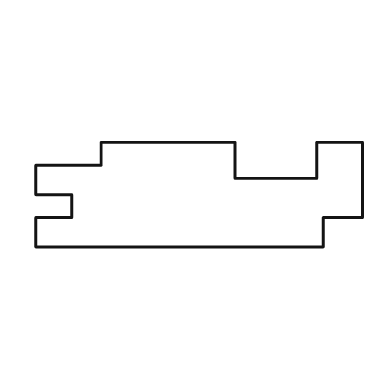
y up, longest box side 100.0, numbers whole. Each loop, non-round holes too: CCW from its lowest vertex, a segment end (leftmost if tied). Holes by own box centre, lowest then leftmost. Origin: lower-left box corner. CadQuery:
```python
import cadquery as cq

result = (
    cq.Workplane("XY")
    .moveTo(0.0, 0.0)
    .lineTo(88.0, 0.0)
    .lineTo(88.0, 9.0)
    .lineTo(100.0, 9.0)
    .lineTo(100.0, 32.0)
    .lineTo(86.0, 32.0)
    .lineTo(86.0, 21.0)
    .lineTo(61.0, 21.0)
    .lineTo(61.0, 32.0)
    .lineTo(20.0, 32.0)
    .lineTo(20.0, 25.0)
    .lineTo(0.0, 25.0)
    .lineTo(0.0, 16.0)
    .lineTo(11.0, 16.0)
    .lineTo(11.0, 9.0)
    .lineTo(0.0, 9.0)
    .close()
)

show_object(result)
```